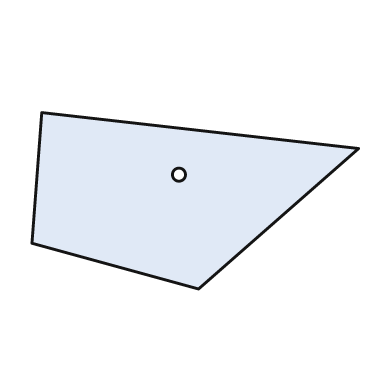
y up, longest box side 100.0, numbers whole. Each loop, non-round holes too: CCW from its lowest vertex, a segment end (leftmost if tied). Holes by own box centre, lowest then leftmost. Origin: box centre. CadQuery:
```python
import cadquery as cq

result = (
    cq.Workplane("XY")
    .moveTo(1.0, -27.0)
    .lineTo(50.0, 16.0)
    .lineTo(-47.0, 27.0)
    .lineTo(-50.0, -13.0)
    .close()
    .moveTo(-5.0, 8.0)
    .circle(2.0)
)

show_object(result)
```